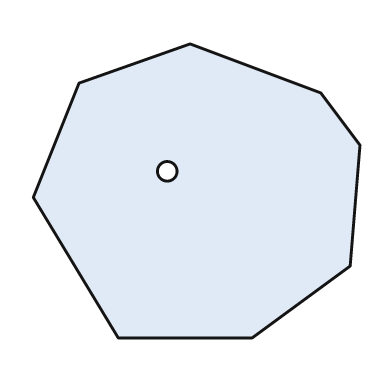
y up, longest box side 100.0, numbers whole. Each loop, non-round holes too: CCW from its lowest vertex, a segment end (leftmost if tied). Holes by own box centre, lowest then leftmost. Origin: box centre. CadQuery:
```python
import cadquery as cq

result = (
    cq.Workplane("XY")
    .moveTo(-24.0, -45.0)
    .lineTo(17.0, -45.0)
    .lineTo(47.0, -23.0)
    .lineTo(50.0, 14.0)
    .lineTo(38.0, 30.0)
    .lineTo(-2.0, 45.0)
    .lineTo(-36.0, 33.0)
    .lineTo(-50.0, -2.0)
    .close()
    .moveTo(-9.0, 6.0)
    .circle(3.0)
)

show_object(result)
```